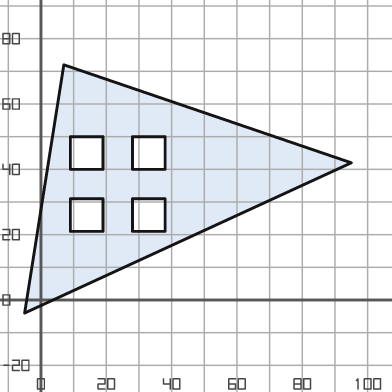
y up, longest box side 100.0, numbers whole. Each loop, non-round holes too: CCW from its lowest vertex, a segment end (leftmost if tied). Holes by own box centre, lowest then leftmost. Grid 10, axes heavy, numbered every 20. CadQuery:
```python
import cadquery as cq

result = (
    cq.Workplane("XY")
    .moveTo(-5.0, -4.0)
    .lineTo(95.0, 42.0)
    .lineTo(7.0, 72.0)
    .close()
    .moveTo(9.0, 21.0)
    .lineTo(19.0, 21.0)
    .lineTo(19.0, 31.0)
    .lineTo(9.0, 31.0)
    .close()
    .moveTo(28.0, 21.0)
    .lineTo(38.0, 21.0)
    .lineTo(38.0, 31.0)
    .lineTo(28.0, 31.0)
    .close()
    .moveTo(9.0, 40.0)
    .lineTo(19.0, 40.0)
    .lineTo(19.0, 50.0)
    .lineTo(9.0, 50.0)
    .close()
    .moveTo(28.0, 40.0)
    .lineTo(38.0, 40.0)
    .lineTo(38.0, 50.0)
    .lineTo(28.0, 50.0)
    .close()
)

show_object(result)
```